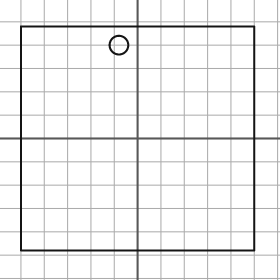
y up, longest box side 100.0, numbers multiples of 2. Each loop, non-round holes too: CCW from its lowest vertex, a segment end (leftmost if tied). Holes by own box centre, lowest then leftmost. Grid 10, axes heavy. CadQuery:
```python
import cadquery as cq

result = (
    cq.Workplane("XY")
    .moveTo(-50.0, -48.0)
    .lineTo(50.0, -48.0)
    .lineTo(50.0, 48.0)
    .lineTo(-50.0, 48.0)
    .close()
    .moveTo(-8.0, 40.0)
    .circle(4.0)
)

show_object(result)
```